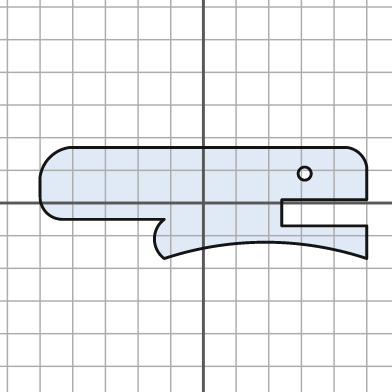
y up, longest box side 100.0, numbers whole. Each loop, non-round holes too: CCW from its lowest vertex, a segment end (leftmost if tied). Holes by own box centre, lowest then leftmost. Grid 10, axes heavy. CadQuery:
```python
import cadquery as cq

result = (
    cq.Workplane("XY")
    .moveTo(-12.0, -17.0)
    .threePointArc((19.0, -12.0), (50.0, -17.0))
    .lineTo(50.0, -7.0)
    .lineTo(24.0, -7.0)
    .lineTo(24.0, 1.0)
    .lineTo(50.0, 1.0)
    .lineTo(50.0, 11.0)
    .threePointArc((48.0, 15.0), (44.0, 17.0))
    .lineTo(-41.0, 17.0)
    .threePointArc((-47.0, 14.0), (-50.0, 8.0))
    .lineTo(-50.0, 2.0)
    .threePointArc((-48.0, -3.0), (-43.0, -5.0))
    .lineTo(-12.0, -5.0)
    .threePointArc((-15.0, -11.0), (-12.0, -17.0))
    .close()
    .moveTo(31.0, 9.0)
    .circle(2.0)
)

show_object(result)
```